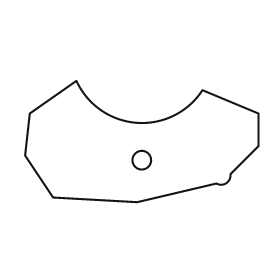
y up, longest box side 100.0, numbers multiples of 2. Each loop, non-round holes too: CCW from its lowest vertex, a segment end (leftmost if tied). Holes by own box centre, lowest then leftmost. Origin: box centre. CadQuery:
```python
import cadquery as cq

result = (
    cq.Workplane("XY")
    .moveTo(-2.0, -26.0)
    .lineTo(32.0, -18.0)
    .threePointArc((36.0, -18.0), (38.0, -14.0))
    .lineTo(50.0, -2.0)
    .lineTo(50.0, 12.0)
    .lineTo(26.0, 22.0)
    .threePointArc((-2.0, 8.0), (-28.0, 26.0))
    .lineTo(-48.0, 12.0)
    .lineTo(-50.0, -6.0)
    .lineTo(-38.0, -24.0)
    .close()
    .moveTo(0.0, -8.0)
    .circle(4.0)
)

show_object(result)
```